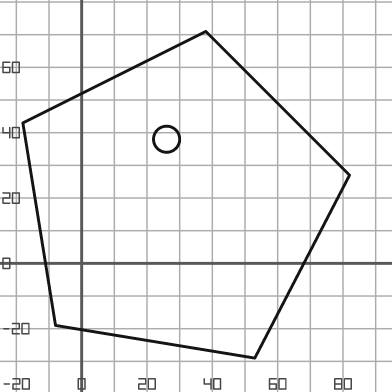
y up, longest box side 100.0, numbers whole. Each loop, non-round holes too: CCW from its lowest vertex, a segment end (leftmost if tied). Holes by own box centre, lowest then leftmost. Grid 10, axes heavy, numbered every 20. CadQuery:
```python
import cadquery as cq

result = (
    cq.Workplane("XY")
    .moveTo(53.0, -29.0)
    .lineTo(82.0, 27.0)
    .lineTo(38.0, 71.0)
    .lineTo(-18.0, 43.0)
    .lineTo(-8.0, -19.0)
    .close()
    .moveTo(26.0, 38.0)
    .circle(4.0)
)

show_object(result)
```